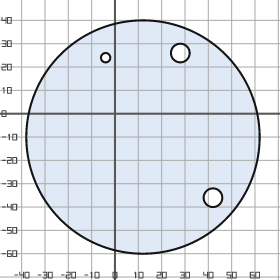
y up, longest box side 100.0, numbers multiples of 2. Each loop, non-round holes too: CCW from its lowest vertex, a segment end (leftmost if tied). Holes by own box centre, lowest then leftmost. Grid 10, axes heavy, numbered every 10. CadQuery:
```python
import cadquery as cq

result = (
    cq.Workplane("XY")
    .moveTo(12.0, -10.0)
    .circle(50.0)
    .moveTo(42.0, -36.0)
    .circle(4.0)
    .moveTo(-4.0, 24.0)
    .circle(2.0)
    .moveTo(28.0, 26.0)
    .circle(4.0)
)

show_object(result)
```